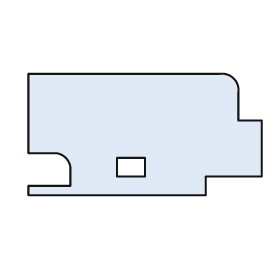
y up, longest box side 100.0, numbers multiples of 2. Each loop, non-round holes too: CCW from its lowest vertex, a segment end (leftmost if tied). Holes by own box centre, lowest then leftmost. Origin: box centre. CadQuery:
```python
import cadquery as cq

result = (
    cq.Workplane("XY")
    .moveTo(-50.0, -26.0)
    .lineTo(26.0, -26.0)
    .lineTo(26.0, -18.0)
    .lineTo(50.0, -18.0)
    .lineTo(50.0, 6.0)
    .lineTo(40.0, 6.0)
    .lineTo(40.0, 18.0)
    .threePointArc((38.0, 24.0), (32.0, 26.0))
    .lineTo(-50.0, 26.0)
    .lineTo(-50.0, -8.0)
    .lineTo(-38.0, -8.0)
    .threePointArc((-34.0, -10.0), (-32.0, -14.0))
    .lineTo(-32.0, -22.0)
    .lineTo(-50.0, -22.0)
    .close()
    .moveTo(-12.0, -18.0)
    .lineTo(0.0, -18.0)
    .lineTo(0.0, -10.0)
    .lineTo(-12.0, -10.0)
    .close()
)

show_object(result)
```